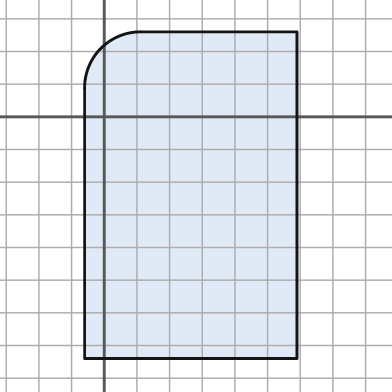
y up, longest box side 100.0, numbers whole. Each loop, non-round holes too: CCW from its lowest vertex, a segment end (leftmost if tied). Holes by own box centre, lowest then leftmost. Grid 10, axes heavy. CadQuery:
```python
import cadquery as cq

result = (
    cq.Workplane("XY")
    .moveTo(-6.0, -74.0)
    .lineTo(59.0, -74.0)
    .lineTo(59.0, 26.0)
    .lineTo(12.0, 26.0)
    .threePointArc((-1.0, 21.0), (-6.0, 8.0))
    .close()
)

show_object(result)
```